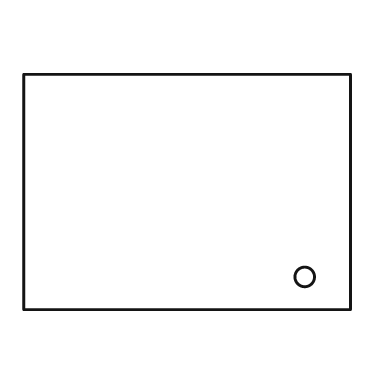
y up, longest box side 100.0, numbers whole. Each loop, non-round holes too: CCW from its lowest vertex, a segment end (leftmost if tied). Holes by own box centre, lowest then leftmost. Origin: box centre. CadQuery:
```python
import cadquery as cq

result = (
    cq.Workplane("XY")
    .moveTo(-50.0, -36.0)
    .lineTo(50.0, -36.0)
    .lineTo(50.0, 36.0)
    .lineTo(-50.0, 36.0)
    .close()
    .moveTo(36.0, -26.0)
    .circle(3.0)
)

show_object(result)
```